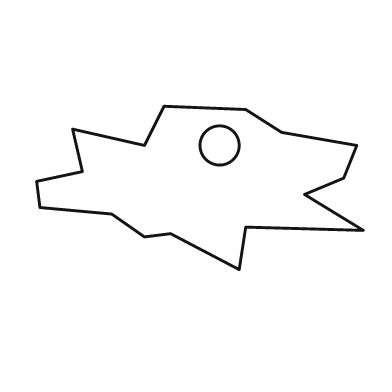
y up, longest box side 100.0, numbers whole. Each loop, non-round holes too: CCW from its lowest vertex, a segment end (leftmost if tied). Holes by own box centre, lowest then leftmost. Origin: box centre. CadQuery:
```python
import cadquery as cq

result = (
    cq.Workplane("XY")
    .moveTo(12.0, -25.0)
    .lineTo(14.0, -12.0)
    .lineTo(50.0, -13.0)
    .lineTo(32.0, -2.0)
    .lineTo(44.0, 3.0)
    .lineTo(48.0, 13.0)
    .lineTo(25.0, 17.0)
    .lineTo(14.0, 24.0)
    .lineTo(-11.0, 25.0)
    .lineTo(-17.0, 13.0)
    .lineTo(-39.0, 18.0)
    .lineTo(-36.0, 5.0)
    .lineTo(-50.0, 2.0)
    .lineTo(-49.0, -6.0)
    .lineTo(-27.0, -8.0)
    .lineTo(-17.0, -15.0)
    .lineTo(-9.0, -14.0)
    .close()
    .moveTo(6.0, 13.0)
    .circle(6.0)
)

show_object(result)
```